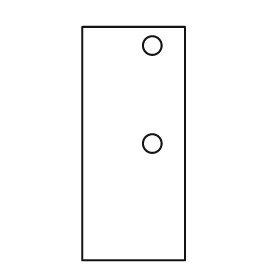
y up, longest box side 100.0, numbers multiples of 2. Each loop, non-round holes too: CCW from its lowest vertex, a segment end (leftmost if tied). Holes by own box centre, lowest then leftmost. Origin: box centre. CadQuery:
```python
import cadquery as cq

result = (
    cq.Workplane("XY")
    .moveTo(-22.0, -50.0)
    .lineTo(22.0, -50.0)
    .lineTo(22.0, 50.0)
    .lineTo(-22.0, 50.0)
    .close()
    .moveTo(8.0, 0.0)
    .circle(4.0)
    .moveTo(8.0, 42.0)
    .circle(4.0)
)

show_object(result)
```